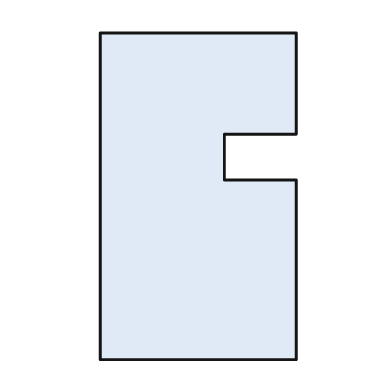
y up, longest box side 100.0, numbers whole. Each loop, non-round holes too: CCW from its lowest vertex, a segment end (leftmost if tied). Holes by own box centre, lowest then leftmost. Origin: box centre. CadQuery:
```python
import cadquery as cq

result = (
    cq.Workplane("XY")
    .moveTo(-30.0, -50.0)
    .lineTo(30.0, -50.0)
    .lineTo(30.0, 5.0)
    .lineTo(8.0, 5.0)
    .lineTo(8.0, 19.0)
    .lineTo(30.0, 19.0)
    .lineTo(30.0, 50.0)
    .lineTo(-30.0, 50.0)
    .close()
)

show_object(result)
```